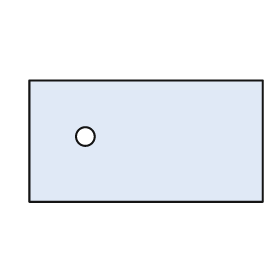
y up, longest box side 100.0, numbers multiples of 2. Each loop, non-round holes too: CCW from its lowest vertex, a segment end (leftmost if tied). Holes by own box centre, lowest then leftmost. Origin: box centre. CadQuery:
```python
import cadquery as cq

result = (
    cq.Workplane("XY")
    .moveTo(-50.0, -26.0)
    .lineTo(50.0, -26.0)
    .lineTo(50.0, 26.0)
    .lineTo(-50.0, 26.0)
    .close()
    .moveTo(-26.0, 2.0)
    .circle(4.0)
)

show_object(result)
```